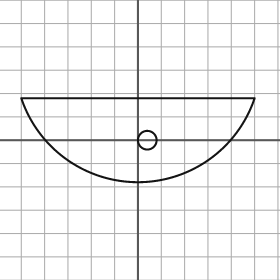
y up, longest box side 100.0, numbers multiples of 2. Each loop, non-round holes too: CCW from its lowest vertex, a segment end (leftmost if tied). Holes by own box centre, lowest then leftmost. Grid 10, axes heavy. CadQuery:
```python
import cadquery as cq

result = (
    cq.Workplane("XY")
    .moveTo(-50.0, 18.0)
    .threePointArc((0.0, -18.0), (50.0, 18.0))
    .close()
    .moveTo(4.0, 0.0)
    .circle(4.0)
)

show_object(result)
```